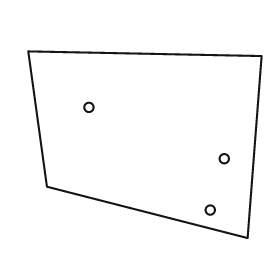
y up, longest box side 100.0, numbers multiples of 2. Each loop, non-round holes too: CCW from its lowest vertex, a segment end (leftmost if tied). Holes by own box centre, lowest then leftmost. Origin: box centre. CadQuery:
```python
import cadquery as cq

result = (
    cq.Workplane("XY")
    .moveTo(44.0, -40.0)
    .lineTo(50.0, 38.0)
    .lineTo(-50.0, 40.0)
    .lineTo(-42.0, -18.0)
    .close()
    .moveTo(28.0, -28.0)
    .circle(2.0)
    .moveTo(34.0, -6.0)
    .circle(2.0)
    .moveTo(-24.0, 16.0)
    .circle(2.0)
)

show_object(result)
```